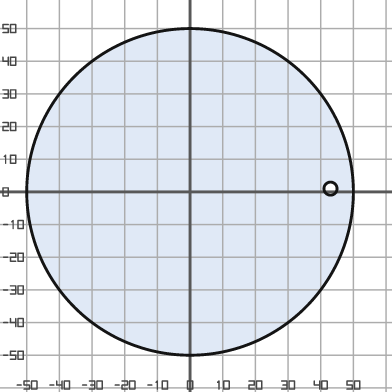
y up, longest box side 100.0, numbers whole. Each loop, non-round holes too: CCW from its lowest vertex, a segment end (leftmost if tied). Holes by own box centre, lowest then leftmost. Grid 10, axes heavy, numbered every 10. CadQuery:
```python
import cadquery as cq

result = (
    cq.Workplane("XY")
    .moveTo(0.0, 0.0)
    .circle(50.0)
    .moveTo(43.0, 1.0)
    .circle(2.0)
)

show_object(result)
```